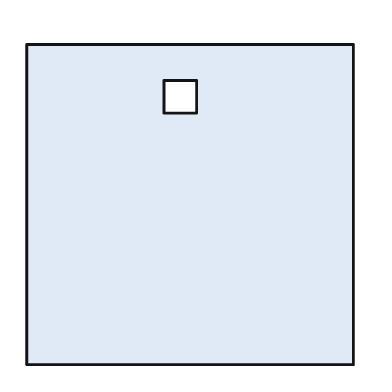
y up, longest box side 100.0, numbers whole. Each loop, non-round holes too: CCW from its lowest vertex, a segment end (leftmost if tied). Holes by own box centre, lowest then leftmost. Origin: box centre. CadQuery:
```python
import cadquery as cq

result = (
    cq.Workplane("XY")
    .moveTo(-50.0, -49.0)
    .lineTo(50.0, -49.0)
    .lineTo(50.0, 49.0)
    .lineTo(-50.0, 49.0)
    .close()
    .moveTo(-8.0, 28.0)
    .lineTo(2.0, 28.0)
    .lineTo(2.0, 38.0)
    .lineTo(-8.0, 38.0)
    .close()
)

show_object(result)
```